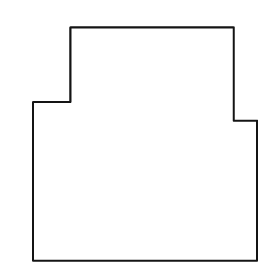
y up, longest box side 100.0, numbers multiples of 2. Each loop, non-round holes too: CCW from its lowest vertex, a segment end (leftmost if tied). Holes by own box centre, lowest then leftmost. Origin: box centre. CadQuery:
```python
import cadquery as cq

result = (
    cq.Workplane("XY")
    .moveTo(-48.0, -50.0)
    .lineTo(48.0, -50.0)
    .lineTo(48.0, 10.0)
    .lineTo(38.0, 10.0)
    .lineTo(38.0, 50.0)
    .lineTo(-32.0, 50.0)
    .lineTo(-32.0, 18.0)
    .lineTo(-48.0, 18.0)
    .close()
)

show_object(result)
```